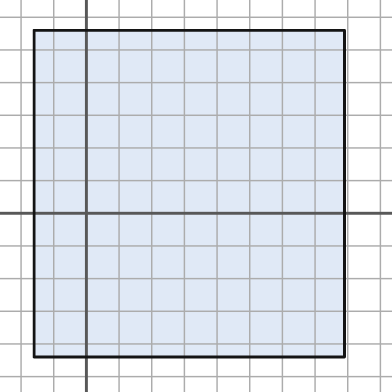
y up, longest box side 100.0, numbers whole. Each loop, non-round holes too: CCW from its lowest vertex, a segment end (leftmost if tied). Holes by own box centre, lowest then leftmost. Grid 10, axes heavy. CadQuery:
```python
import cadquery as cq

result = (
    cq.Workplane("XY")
    .moveTo(-16.0, -44.0)
    .lineTo(79.0, -44.0)
    .lineTo(79.0, 56.0)
    .lineTo(-16.0, 56.0)
    .close()
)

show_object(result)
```